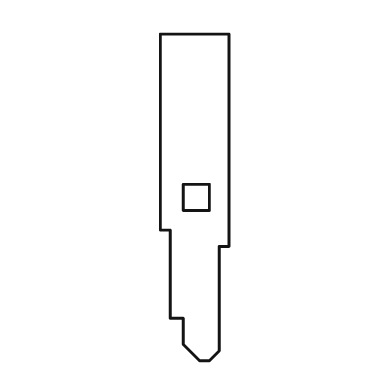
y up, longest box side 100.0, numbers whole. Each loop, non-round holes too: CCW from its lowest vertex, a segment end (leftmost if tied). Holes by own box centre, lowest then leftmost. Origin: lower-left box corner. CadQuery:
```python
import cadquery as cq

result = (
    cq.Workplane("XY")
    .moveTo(12.0, 0.0)
    .lineTo(15.0, 0.0)
    .lineTo(18.0, 3.0)
    .lineTo(18.0, 35.0)
    .lineTo(21.0, 35.0)
    .lineTo(21.0, 100.0)
    .lineTo(0.0, 100.0)
    .lineTo(0.0, 40.0)
    .lineTo(3.0, 40.0)
    .lineTo(3.0, 13.0)
    .lineTo(7.0, 13.0)
    .lineTo(7.0, 5.0)
    .close()
    .moveTo(7.0, 46.0)
    .lineTo(15.0, 46.0)
    .lineTo(15.0, 54.0)
    .lineTo(7.0, 54.0)
    .close()
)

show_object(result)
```